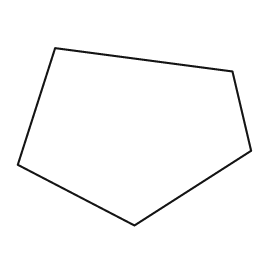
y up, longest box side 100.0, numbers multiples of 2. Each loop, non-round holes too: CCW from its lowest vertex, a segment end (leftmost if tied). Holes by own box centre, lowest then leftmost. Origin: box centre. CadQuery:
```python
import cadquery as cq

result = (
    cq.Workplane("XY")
    .moveTo(0.0, -38.0)
    .lineTo(50.0, -6.0)
    .lineTo(42.0, 28.0)
    .lineTo(-34.0, 38.0)
    .lineTo(-50.0, -12.0)
    .close()
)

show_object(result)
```